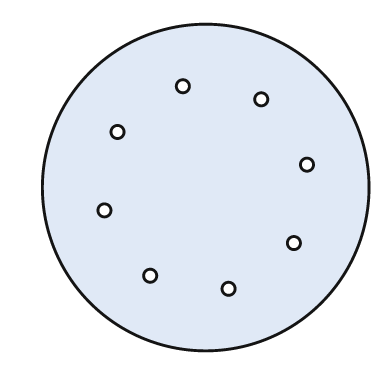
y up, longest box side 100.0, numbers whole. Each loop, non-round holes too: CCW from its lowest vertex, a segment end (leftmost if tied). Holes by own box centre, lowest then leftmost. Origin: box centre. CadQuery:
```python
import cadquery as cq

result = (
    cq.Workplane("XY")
    .moveTo(0.0, 0.0)
    .circle(50.0)
    .moveTo(7.0, -31.0)
    .circle(2.0)
    .moveTo(-17.0, -27.0)
    .circle(2.0)
    .moveTo(27.0, -17.0)
    .circle(2.0)
    .moveTo(-31.0, -7.0)
    .circle(2.0)
    .moveTo(31.0, 7.0)
    .circle(2.0)
    .moveTo(-27.0, 17.0)
    .circle(2.0)
    .moveTo(17.0, 27.0)
    .circle(2.0)
    .moveTo(-7.0, 31.0)
    .circle(2.0)
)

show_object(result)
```